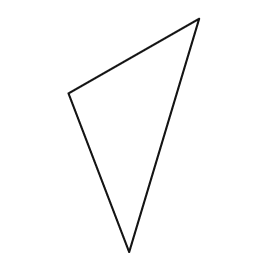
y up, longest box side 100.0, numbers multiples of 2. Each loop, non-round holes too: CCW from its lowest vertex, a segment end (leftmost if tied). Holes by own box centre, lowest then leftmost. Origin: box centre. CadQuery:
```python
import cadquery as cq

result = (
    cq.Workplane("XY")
    .moveTo(-2.0, -50.0)
    .lineTo(28.0, 50.0)
    .lineTo(-28.0, 18.0)
    .close()
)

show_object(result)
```